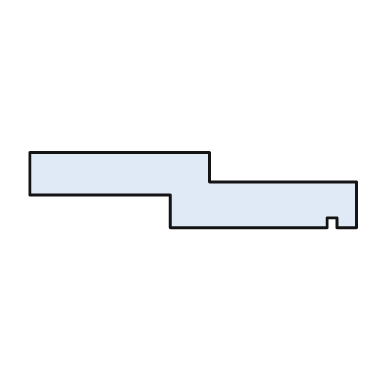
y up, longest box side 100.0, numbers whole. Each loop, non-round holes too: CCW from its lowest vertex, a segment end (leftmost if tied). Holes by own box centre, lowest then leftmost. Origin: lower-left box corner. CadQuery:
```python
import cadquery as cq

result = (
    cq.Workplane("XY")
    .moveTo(43.0, 0.0)
    .lineTo(91.0, 0.0)
    .lineTo(91.0, 3.0)
    .lineTo(94.0, 3.0)
    .lineTo(94.0, 0.0)
    .lineTo(100.0, 0.0)
    .lineTo(100.0, 14.0)
    .lineTo(55.0, 14.0)
    .lineTo(55.0, 23.0)
    .lineTo(0.0, 23.0)
    .lineTo(0.0, 10.0)
    .lineTo(43.0, 10.0)
    .close()
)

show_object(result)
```